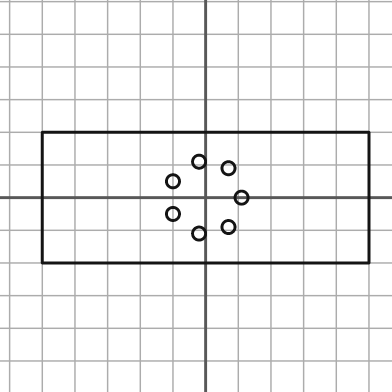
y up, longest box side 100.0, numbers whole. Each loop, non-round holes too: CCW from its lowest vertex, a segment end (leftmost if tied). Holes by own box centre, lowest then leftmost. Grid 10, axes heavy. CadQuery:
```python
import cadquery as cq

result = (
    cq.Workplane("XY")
    .moveTo(-50.0, -20.0)
    .lineTo(50.0, -20.0)
    .lineTo(50.0, 20.0)
    .lineTo(-50.0, 20.0)
    .close()
    .moveTo(-2.0, -11.0)
    .circle(2.0)
    .moveTo(7.0, -9.0)
    .circle(2.0)
    .moveTo(-10.0, -5.0)
    .circle(2.0)
    .moveTo(11.0, 0.0)
    .circle(2.0)
    .moveTo(-10.0, 5.0)
    .circle(2.0)
    .moveTo(7.0, 9.0)
    .circle(2.0)
    .moveTo(-2.0, 11.0)
    .circle(2.0)
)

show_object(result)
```